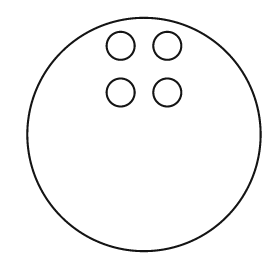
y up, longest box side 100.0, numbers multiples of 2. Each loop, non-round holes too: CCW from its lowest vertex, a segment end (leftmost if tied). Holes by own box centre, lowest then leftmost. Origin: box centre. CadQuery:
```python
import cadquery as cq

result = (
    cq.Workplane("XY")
    .moveTo(0.0, 0.0)
    .circle(50.0)
    .moveTo(-10.0, 18.0)
    .circle(6.0)
    .moveTo(10.0, 18.0)
    .circle(6.0)
    .moveTo(-10.0, 38.0)
    .circle(6.0)
    .moveTo(10.0, 38.0)
    .circle(6.0)
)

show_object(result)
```